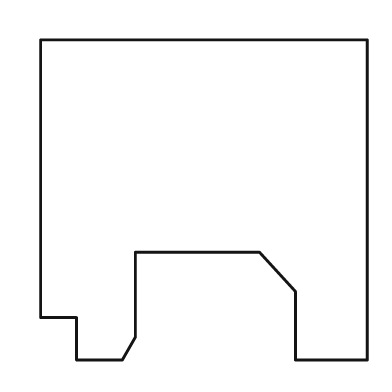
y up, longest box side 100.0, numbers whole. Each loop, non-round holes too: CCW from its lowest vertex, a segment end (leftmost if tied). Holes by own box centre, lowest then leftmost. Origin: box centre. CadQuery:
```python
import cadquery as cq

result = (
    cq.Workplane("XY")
    .moveTo(-39.0, -49.0)
    .lineTo(-25.0, -49.0)
    .lineTo(-21.0, -42.0)
    .lineTo(-21.0, -16.0)
    .lineTo(17.0, -16.0)
    .lineTo(28.0, -28.0)
    .lineTo(28.0, -49.0)
    .lineTo(50.0, -49.0)
    .lineTo(50.0, 49.0)
    .lineTo(-50.0, 49.0)
    .lineTo(-50.0, -36.0)
    .lineTo(-39.0, -36.0)
    .close()
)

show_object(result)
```